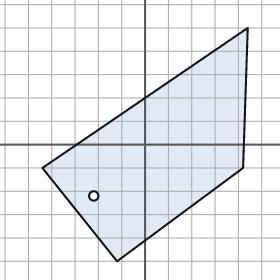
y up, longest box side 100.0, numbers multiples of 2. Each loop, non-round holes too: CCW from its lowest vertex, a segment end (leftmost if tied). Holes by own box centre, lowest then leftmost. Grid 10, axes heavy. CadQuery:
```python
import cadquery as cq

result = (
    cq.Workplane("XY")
    .moveTo(-12.0, -50.0)
    .lineTo(42.0, -10.0)
    .lineTo(44.0, 50.0)
    .lineTo(-44.0, -10.0)
    .close()
    .moveTo(-22.0, -22.0)
    .circle(2.0)
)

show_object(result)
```